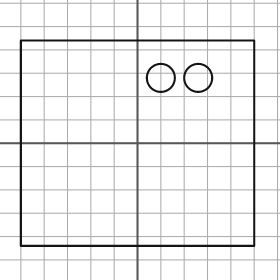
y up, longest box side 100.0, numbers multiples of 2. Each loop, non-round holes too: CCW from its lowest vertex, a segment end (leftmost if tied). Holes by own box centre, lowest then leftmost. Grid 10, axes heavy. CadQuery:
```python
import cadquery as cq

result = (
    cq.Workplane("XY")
    .moveTo(-50.0, -44.0)
    .lineTo(50.0, -44.0)
    .lineTo(50.0, 44.0)
    .lineTo(-50.0, 44.0)
    .close()
    .moveTo(10.0, 28.0)
    .circle(6.0)
    .moveTo(26.0, 28.0)
    .circle(6.0)
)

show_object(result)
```